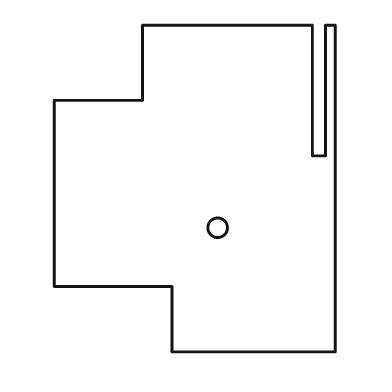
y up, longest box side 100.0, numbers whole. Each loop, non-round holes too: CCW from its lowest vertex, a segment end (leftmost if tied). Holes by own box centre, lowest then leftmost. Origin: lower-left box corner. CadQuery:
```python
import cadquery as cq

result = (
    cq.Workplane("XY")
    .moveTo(36.0, 0.0)
    .lineTo(86.0, 0.0)
    .lineTo(86.0, 100.0)
    .lineTo(83.0, 100.0)
    .lineTo(83.0, 60.0)
    .lineTo(79.0, 60.0)
    .lineTo(79.0, 100.0)
    .lineTo(27.0, 100.0)
    .lineTo(27.0, 77.0)
    .lineTo(0.0, 77.0)
    .lineTo(0.0, 20.0)
    .lineTo(36.0, 20.0)
    .close()
    .moveTo(50.0, 38.0)
    .circle(3.0)
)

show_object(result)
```